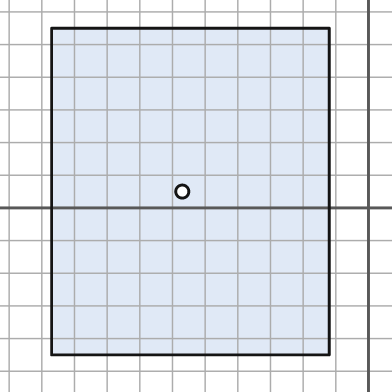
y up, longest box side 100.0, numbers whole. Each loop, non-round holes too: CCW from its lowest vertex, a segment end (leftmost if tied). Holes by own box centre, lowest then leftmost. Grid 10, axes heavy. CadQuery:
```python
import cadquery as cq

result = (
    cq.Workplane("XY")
    .moveTo(-97.0, -45.0)
    .lineTo(-12.0, -45.0)
    .lineTo(-12.0, 55.0)
    .lineTo(-97.0, 55.0)
    .close()
    .moveTo(-57.0, 5.0)
    .circle(2.0)
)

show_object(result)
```